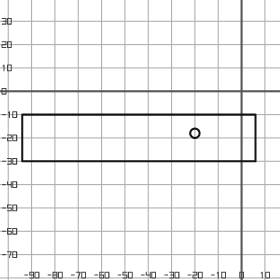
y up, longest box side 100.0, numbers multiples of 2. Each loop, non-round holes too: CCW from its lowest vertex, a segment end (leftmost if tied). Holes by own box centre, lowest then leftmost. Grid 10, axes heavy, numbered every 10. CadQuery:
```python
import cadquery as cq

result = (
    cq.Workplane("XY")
    .moveTo(-94.0, -30.0)
    .lineTo(6.0, -30.0)
    .lineTo(6.0, -10.0)
    .lineTo(-94.0, -10.0)
    .close()
    .moveTo(-20.0, -18.0)
    .circle(2.0)
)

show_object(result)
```